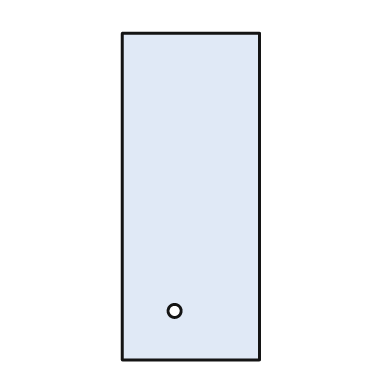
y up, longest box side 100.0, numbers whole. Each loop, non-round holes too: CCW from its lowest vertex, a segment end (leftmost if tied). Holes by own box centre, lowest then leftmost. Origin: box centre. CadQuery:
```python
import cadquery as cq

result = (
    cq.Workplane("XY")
    .moveTo(-21.0, -50.0)
    .lineTo(21.0, -50.0)
    .lineTo(21.0, 50.0)
    .lineTo(-21.0, 50.0)
    .close()
    .moveTo(-5.0, -35.0)
    .circle(2.0)
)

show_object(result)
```